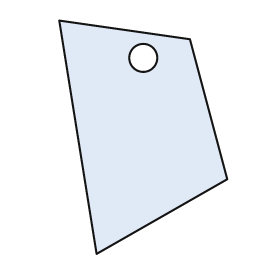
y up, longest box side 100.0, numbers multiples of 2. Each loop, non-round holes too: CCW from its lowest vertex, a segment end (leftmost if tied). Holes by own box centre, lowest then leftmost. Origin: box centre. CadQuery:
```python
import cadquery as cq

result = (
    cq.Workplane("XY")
    .moveTo(-20.0, -50.0)
    .lineTo(36.0, -18.0)
    .lineTo(20.0, 42.0)
    .lineTo(-36.0, 50.0)
    .close()
    .moveTo(0.0, 34.0)
    .circle(6.0)
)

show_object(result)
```